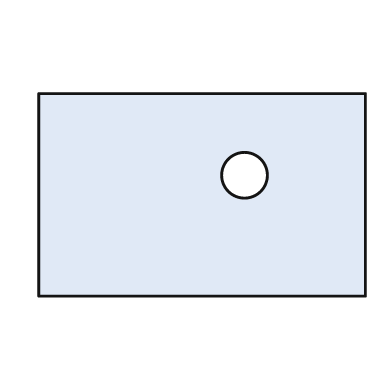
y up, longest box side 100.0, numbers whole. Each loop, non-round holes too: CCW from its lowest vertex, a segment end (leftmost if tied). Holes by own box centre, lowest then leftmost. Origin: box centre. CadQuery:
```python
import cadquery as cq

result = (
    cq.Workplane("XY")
    .moveTo(-50.0, -31.0)
    .lineTo(50.0, -31.0)
    .lineTo(50.0, 31.0)
    .lineTo(-50.0, 31.0)
    .close()
    .moveTo(13.0, 6.0)
    .circle(7.0)
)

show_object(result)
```